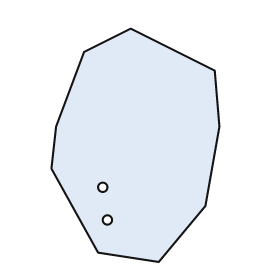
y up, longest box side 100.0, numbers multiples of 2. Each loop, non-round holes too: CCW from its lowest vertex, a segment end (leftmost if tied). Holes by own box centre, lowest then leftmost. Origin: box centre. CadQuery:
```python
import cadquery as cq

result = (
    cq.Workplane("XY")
    .moveTo(10.0, -50.0)
    .lineTo(30.0, -26.0)
    .lineTo(36.0, 8.0)
    .lineTo(34.0, 32.0)
    .lineTo(-2.0, 50.0)
    .lineTo(-22.0, 40.0)
    .lineTo(-34.0, 8.0)
    .lineTo(-36.0, -10.0)
    .lineTo(-16.0, -46.0)
    .close()
    .moveTo(-12.0, -32.0)
    .circle(2.0)
    .moveTo(-14.0, -18.0)
    .circle(2.0)
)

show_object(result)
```